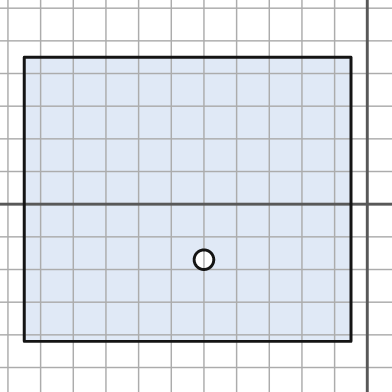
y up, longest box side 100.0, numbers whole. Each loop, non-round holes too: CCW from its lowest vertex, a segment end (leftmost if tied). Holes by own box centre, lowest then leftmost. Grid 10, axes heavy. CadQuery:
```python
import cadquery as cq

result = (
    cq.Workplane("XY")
    .moveTo(-105.0, -42.0)
    .lineTo(-5.0, -42.0)
    .lineTo(-5.0, 45.0)
    .lineTo(-105.0, 45.0)
    .close()
    .moveTo(-50.0, -17.0)
    .circle(3.0)
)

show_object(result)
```